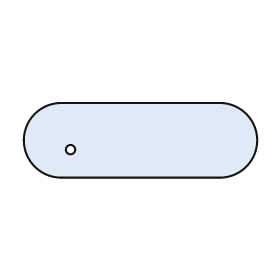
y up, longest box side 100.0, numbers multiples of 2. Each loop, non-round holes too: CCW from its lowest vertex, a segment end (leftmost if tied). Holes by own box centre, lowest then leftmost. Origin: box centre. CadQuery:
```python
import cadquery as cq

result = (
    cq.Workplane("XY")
    .moveTo(-34.0, -16.0)
    .lineTo(34.0, -16.0)
    .threePointArc((50.0, 0.0), (34.0, 16.0))
    .lineTo(-34.0, 16.0)
    .threePointArc((-50.0, 0.0), (-34.0, -16.0))
    .close()
    .moveTo(-30.0, -4.0)
    .circle(2.0)
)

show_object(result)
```